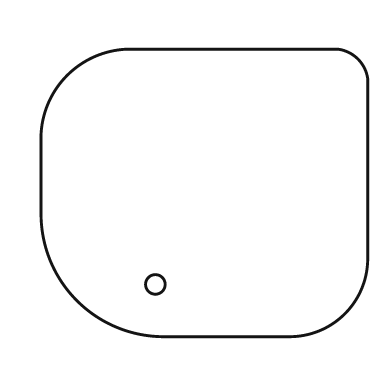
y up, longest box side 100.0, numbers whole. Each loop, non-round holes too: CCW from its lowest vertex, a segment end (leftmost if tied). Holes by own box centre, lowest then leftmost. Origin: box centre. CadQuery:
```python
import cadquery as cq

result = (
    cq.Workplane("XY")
    .moveTo(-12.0, -44.0)
    .lineTo(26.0, -44.0)
    .threePointArc((43.0, -37.0), (50.0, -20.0))
    .lineTo(50.0, 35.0)
    .threePointArc((47.0, 41.0), (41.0, 44.0))
    .lineTo(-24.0, 44.0)
    .threePointArc((-42.0, 36.0), (-50.0, 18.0))
    .lineTo(-50.0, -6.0)
    .threePointArc((-39.0, -33.0), (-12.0, -44.0))
    .close()
    .moveTo(-15.0, -28.0)
    .circle(3.0)
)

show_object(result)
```